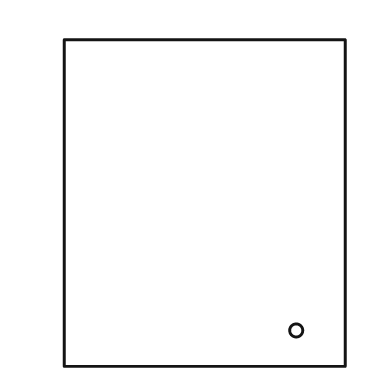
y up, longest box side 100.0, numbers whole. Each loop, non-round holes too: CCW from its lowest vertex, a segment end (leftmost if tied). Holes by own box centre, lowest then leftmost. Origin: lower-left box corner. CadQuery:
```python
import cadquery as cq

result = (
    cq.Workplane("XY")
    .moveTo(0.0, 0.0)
    .lineTo(86.0, 0.0)
    .lineTo(86.0, 100.0)
    .lineTo(0.0, 100.0)
    .close()
    .moveTo(71.0, 11.0)
    .circle(2.0)
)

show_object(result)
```